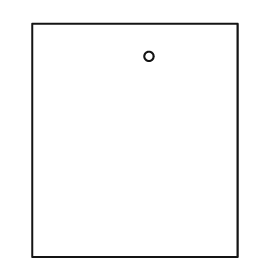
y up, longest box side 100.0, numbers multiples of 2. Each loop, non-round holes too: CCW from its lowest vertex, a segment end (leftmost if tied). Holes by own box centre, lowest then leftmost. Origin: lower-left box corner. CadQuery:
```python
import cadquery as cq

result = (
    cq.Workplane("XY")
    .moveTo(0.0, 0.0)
    .lineTo(88.0, 0.0)
    .lineTo(88.0, 100.0)
    .lineTo(0.0, 100.0)
    .close()
    .moveTo(50.0, 86.0)
    .circle(2.0)
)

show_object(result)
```